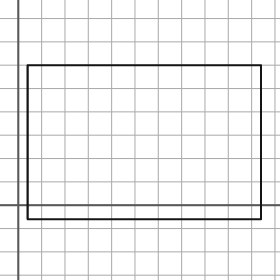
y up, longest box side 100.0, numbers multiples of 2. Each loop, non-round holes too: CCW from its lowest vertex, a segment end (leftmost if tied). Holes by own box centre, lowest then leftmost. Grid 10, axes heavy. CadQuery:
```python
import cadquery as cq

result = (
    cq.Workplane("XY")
    .moveTo(4.0, -6.0)
    .lineTo(104.0, -6.0)
    .lineTo(104.0, 60.0)
    .lineTo(4.0, 60.0)
    .close()
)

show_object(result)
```